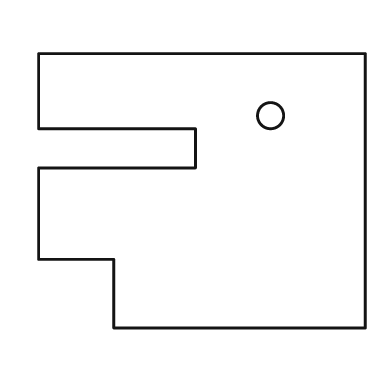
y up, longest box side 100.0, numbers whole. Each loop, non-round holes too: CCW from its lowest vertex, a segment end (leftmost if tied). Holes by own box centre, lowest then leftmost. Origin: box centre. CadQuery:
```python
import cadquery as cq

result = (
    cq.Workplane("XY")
    .moveTo(-27.0, -42.0)
    .lineTo(50.0, -42.0)
    .lineTo(50.0, 42.0)
    .lineTo(-50.0, 42.0)
    .lineTo(-50.0, 19.0)
    .lineTo(-2.0, 19.0)
    .lineTo(-2.0, 7.0)
    .lineTo(-50.0, 7.0)
    .lineTo(-50.0, -21.0)
    .lineTo(-27.0, -21.0)
    .close()
    .moveTo(21.0, 23.0)
    .circle(4.0)
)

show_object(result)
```